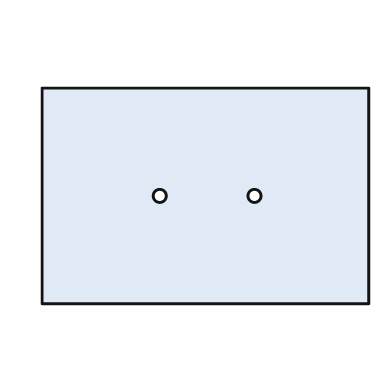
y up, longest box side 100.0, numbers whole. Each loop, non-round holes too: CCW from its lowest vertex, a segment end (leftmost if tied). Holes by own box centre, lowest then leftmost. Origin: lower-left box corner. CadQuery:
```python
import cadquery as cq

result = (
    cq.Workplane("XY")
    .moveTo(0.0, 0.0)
    .lineTo(100.0, 0.0)
    .lineTo(100.0, 66.0)
    .lineTo(0.0, 66.0)
    .close()
    .moveTo(36.0, 33.0)
    .circle(2.0)
    .moveTo(65.0, 33.0)
    .circle(2.0)
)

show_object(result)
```